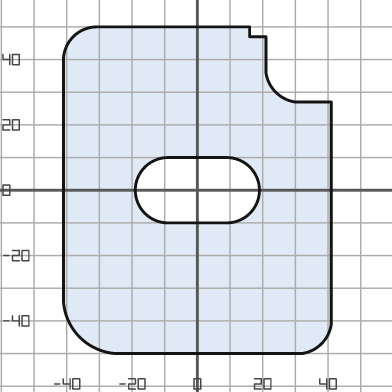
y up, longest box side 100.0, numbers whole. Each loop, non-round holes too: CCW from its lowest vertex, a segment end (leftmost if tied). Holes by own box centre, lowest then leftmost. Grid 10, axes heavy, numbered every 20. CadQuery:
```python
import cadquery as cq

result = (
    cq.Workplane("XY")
    .moveTo(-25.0, -50.0)
    .lineTo(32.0, -50.0)
    .threePointArc((38.0, -47.0), (41.0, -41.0))
    .lineTo(41.0, 27.0)
    .lineTo(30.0, 27.0)
    .threePointArc((24.0, 30.0), (21.0, 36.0))
    .lineTo(21.0, 47.0)
    .lineTo(16.0, 47.0)
    .lineTo(16.0, 50.0)
    .lineTo(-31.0, 50.0)
    .threePointArc((-38.0, 47.0), (-41.0, 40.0))
    .lineTo(-41.0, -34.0)
    .threePointArc((-36.0, -45.0), (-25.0, -50.0))
    .close()
    .moveTo(-9.0, -10.0)
    .lineTo(9.0, -10.0)
    .threePointArc((19.0, 0.0), (9.0, 10.0))
    .lineTo(-9.0, 10.0)
    .threePointArc((-19.0, 0.0), (-9.0, -10.0))
    .close()
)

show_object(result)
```